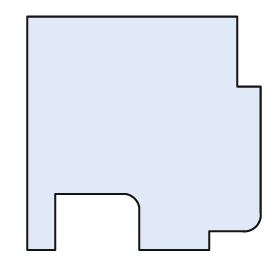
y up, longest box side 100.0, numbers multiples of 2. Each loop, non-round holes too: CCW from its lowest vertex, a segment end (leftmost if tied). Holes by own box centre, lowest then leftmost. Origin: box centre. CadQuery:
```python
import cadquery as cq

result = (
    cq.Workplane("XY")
    .moveTo(-50.0, -50.0)
    .lineTo(-38.0, -50.0)
    .lineTo(-38.0, -26.0)
    .lineTo(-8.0, -26.0)
    .threePointArc((-4.0, -28.0), (-2.0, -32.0))
    .lineTo(-2.0, -50.0)
    .lineTo(28.0, -50.0)
    .lineTo(28.0, -42.0)
    .lineTo(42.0, -42.0)
    .threePointArc((48.0, -40.0), (50.0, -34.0))
    .lineTo(50.0, 20.0)
    .lineTo(40.0, 20.0)
    .lineTo(40.0, 50.0)
    .lineTo(-50.0, 50.0)
    .close()
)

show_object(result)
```